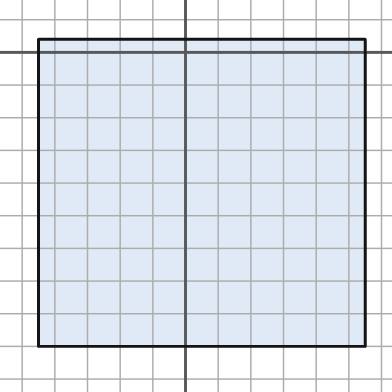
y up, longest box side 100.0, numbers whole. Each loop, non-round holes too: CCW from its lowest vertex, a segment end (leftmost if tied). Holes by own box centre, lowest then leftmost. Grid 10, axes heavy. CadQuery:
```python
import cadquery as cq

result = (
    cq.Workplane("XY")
    .moveTo(-45.0, -90.0)
    .lineTo(55.0, -90.0)
    .lineTo(55.0, 4.0)
    .lineTo(-45.0, 4.0)
    .close()
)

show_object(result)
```